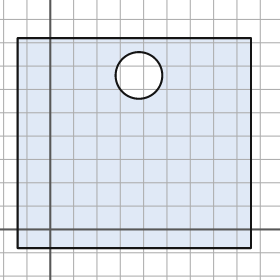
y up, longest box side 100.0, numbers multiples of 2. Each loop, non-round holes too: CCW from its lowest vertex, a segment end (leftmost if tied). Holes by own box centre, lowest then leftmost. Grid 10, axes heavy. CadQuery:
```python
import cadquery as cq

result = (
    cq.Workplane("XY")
    .moveTo(-14.0, -8.0)
    .lineTo(86.0, -8.0)
    .lineTo(86.0, 82.0)
    .lineTo(-14.0, 82.0)
    .close()
    .moveTo(38.0, 66.0)
    .circle(10.0)
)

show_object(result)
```